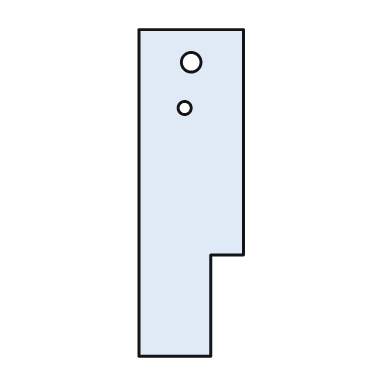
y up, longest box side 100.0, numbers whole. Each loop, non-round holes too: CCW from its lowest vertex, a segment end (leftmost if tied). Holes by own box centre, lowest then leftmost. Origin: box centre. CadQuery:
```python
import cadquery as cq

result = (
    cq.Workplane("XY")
    .moveTo(-16.0, -50.0)
    .lineTo(6.0, -50.0)
    .lineTo(6.0, -19.0)
    .lineTo(16.0, -19.0)
    .lineTo(16.0, 50.0)
    .lineTo(-16.0, 50.0)
    .close()
    .moveTo(-2.0, 26.0)
    .circle(2.0)
    .moveTo(0.0, 40.0)
    .circle(3.0)
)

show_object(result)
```